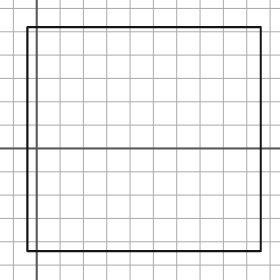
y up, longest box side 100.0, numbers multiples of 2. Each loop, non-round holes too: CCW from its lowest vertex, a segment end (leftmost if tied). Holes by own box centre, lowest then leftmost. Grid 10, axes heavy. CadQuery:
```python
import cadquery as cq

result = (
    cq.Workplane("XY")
    .moveTo(-4.0, -44.0)
    .lineTo(96.0, -44.0)
    .lineTo(96.0, 52.0)
    .lineTo(-4.0, 52.0)
    .close()
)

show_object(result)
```